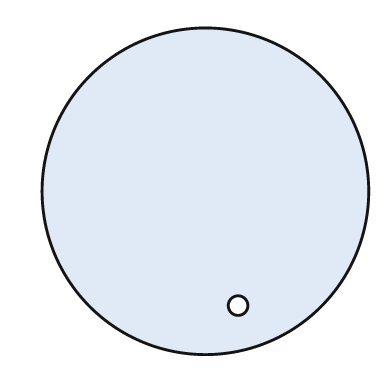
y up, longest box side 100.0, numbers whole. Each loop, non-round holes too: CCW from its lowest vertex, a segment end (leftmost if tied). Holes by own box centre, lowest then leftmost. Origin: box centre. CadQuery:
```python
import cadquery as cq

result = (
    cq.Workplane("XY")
    .moveTo(0.0, 0.0)
    .circle(50.0)
    .moveTo(10.0, -35.0)
    .circle(3.0)
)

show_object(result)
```